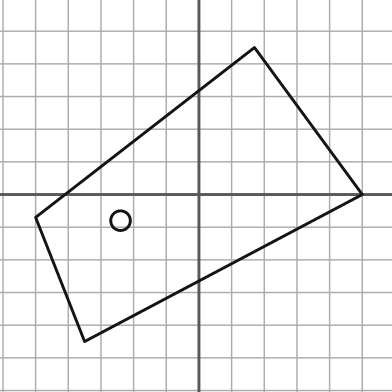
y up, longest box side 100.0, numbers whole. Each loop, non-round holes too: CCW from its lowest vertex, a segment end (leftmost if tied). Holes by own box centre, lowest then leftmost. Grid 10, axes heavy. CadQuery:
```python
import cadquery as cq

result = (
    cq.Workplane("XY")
    .moveTo(-35.0, -45.0)
    .lineTo(50.0, 0.0)
    .lineTo(17.0, 45.0)
    .lineTo(-50.0, -7.0)
    .close()
    .moveTo(-24.0, -8.0)
    .circle(3.0)
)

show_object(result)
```